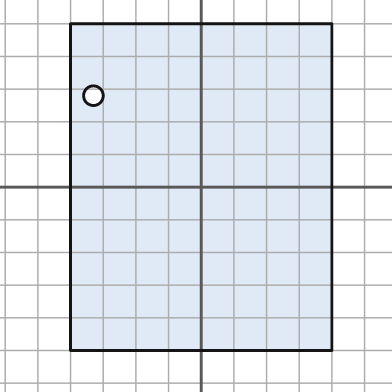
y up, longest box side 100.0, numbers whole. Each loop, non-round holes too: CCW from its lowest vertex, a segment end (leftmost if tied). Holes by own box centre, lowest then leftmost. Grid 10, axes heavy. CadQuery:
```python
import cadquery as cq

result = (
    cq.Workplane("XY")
    .moveTo(-40.0, -50.0)
    .lineTo(40.0, -50.0)
    .lineTo(40.0, 50.0)
    .lineTo(-40.0, 50.0)
    .close()
    .moveTo(-33.0, 28.0)
    .circle(3.0)
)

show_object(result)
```